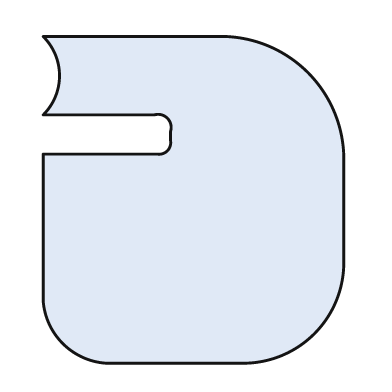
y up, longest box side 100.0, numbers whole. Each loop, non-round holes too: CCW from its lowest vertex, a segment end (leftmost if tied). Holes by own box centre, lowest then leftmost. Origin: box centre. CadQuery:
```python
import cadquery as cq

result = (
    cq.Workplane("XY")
    .moveTo(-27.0, -50.0)
    .lineTo(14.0, -50.0)
    .threePointArc((37.0, -41.0), (46.0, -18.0))
    .lineTo(46.0, 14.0)
    .threePointArc((35.0, 39.0), (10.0, 50.0))
    .lineTo(-46.0, 50.0)
    .threePointArc((-41.0, 38.0), (-46.0, 26.0))
    .lineTo(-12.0, 26.0)
    .threePointArc((-8.0, 25.0), (-7.0, 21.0))
    .lineTo(-7.0, 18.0)
    .threePointArc((-8.0, 15.0), (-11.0, 14.0))
    .lineTo(-46.0, 14.0)
    .lineTo(-46.0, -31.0)
    .threePointArc((-40.0, -44.0), (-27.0, -50.0))
    .close()
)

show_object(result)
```